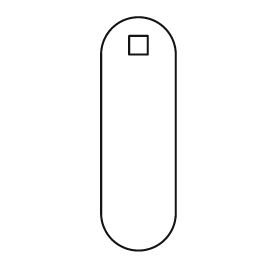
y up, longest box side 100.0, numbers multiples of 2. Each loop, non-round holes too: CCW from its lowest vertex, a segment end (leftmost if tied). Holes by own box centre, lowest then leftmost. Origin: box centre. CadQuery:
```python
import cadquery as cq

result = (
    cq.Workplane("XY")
    .moveTo(-16.0, -34.0)
    .threePointArc((0.0, -50.0), (16.0, -34.0))
    .lineTo(16.0, 34.0)
    .threePointArc((0.0, 50.0), (-16.0, 34.0))
    .close()
    .moveTo(-4.0, 34.0)
    .lineTo(4.0, 34.0)
    .lineTo(4.0, 42.0)
    .lineTo(-4.0, 42.0)
    .close()
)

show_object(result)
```